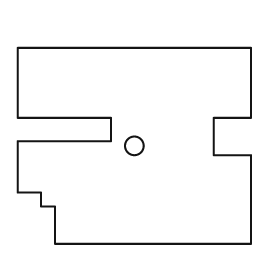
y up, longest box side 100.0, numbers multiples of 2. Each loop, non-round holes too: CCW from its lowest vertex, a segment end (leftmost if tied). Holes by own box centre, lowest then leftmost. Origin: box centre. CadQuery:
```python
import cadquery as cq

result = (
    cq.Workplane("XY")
    .moveTo(-34.0, -42.0)
    .lineTo(50.0, -42.0)
    .lineTo(50.0, -4.0)
    .lineTo(34.0, -4.0)
    .lineTo(34.0, 12.0)
    .lineTo(50.0, 12.0)
    .lineTo(50.0, 42.0)
    .lineTo(-50.0, 42.0)
    .lineTo(-50.0, 12.0)
    .lineTo(-10.0, 12.0)
    .lineTo(-10.0, 2.0)
    .lineTo(-50.0, 2.0)
    .lineTo(-50.0, -20.0)
    .lineTo(-40.0, -20.0)
    .lineTo(-40.0, -26.0)
    .lineTo(-34.0, -26.0)
    .close()
    .moveTo(0.0, 0.0)
    .circle(4.0)
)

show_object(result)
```